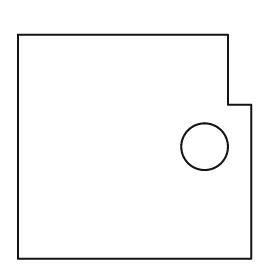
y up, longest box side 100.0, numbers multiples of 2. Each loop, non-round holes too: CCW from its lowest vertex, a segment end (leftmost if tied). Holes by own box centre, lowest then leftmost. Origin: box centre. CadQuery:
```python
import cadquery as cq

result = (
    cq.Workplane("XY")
    .moveTo(-50.0, -48.0)
    .lineTo(50.0, -48.0)
    .lineTo(50.0, 18.0)
    .lineTo(40.0, 18.0)
    .lineTo(40.0, 48.0)
    .lineTo(-50.0, 48.0)
    .close()
    .moveTo(30.0, 0.0)
    .circle(10.0)
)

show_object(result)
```